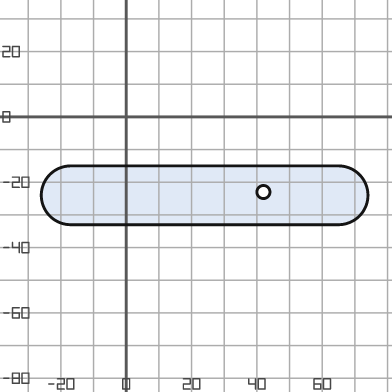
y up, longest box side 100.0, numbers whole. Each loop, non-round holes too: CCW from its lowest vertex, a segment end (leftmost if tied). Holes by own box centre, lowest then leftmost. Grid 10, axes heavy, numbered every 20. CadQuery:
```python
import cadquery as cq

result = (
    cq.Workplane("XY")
    .moveTo(-17.0, -33.0)
    .lineTo(65.0, -33.0)
    .threePointArc((74.0, -24.0), (65.0, -15.0))
    .lineTo(-17.0, -15.0)
    .threePointArc((-26.0, -24.0), (-17.0, -33.0))
    .close()
    .moveTo(42.0, -23.0)
    .circle(2.0)
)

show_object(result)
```